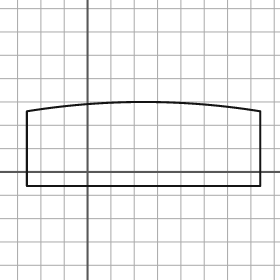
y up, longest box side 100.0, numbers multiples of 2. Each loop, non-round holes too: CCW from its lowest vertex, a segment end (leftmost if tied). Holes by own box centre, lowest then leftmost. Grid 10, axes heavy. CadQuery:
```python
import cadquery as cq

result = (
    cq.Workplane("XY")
    .moveTo(-26.0, -6.0)
    .lineTo(74.0, -6.0)
    .lineTo(74.0, 26.0)
    .threePointArc((24.0, 30.0), (-26.0, 26.0))
    .close()
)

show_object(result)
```